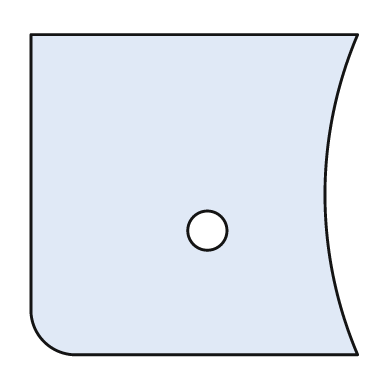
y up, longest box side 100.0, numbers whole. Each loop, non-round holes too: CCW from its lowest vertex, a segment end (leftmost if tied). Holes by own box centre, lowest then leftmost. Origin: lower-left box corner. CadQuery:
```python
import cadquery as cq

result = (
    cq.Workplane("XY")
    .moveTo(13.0, 0.0)
    .lineTo(100.0, 0.0)
    .threePointArc((90.0, 49.0), (100.0, 98.0))
    .lineTo(0.0, 98.0)
    .lineTo(0.0, 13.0)
    .threePointArc((4.0, 4.0), (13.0, 0.0))
    .close()
    .moveTo(54.0, 38.0)
    .circle(6.0)
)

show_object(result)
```